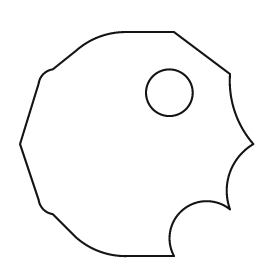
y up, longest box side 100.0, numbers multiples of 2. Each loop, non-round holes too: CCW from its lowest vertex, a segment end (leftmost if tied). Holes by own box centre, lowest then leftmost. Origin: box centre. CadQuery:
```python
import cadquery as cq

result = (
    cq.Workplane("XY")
    .moveTo(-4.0, -48.0)
    .lineTo(16.0, -48.0)
    .threePointArc((20.0, -28.0), (40.0, -28.0))
    .threePointArc((40.0, -12.0), (50.0, 0.0))
    .threePointArc((42.0, 14.0), (40.0, 30.0))
    .lineTo(16.0, 48.0)
    .lineTo(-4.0, 48.0)
    .threePointArc((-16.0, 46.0), (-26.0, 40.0))
    .lineTo(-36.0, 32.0)
    .threePointArc((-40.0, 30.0), (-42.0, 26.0))
    .lineTo(-50.0, 0.0)
    .lineTo(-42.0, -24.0)
    .threePointArc((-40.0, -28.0), (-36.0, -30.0))
    .lineTo(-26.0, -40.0)
    .threePointArc((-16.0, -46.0), (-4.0, -48.0))
    .close()
    .moveTo(14.0, 22.0)
    .circle(10.0)
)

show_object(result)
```